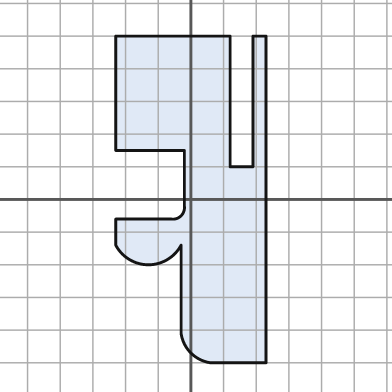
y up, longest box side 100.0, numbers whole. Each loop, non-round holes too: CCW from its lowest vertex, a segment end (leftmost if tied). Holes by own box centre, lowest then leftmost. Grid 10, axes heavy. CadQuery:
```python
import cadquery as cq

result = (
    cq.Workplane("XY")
    .moveTo(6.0, -50.0)
    .lineTo(23.0, -50.0)
    .lineTo(23.0, 50.0)
    .lineTo(19.0, 50.0)
    .lineTo(19.0, 10.0)
    .lineTo(12.0, 10.0)
    .lineTo(12.0, 50.0)
    .lineTo(-23.0, 50.0)
    .lineTo(-23.0, 15.0)
    .lineTo(-2.0, 15.0)
    .lineTo(-2.0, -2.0)
    .threePointArc((-3.0, -5.0), (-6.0, -6.0))
    .lineTo(-23.0, -6.0)
    .lineTo(-23.0, -14.0)
    .threePointArc((-13.0, -20.0), (-3.0, -14.0))
    .lineTo(-3.0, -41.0)
    .threePointArc((0.0, -47.0), (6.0, -50.0))
    .close()
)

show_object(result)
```